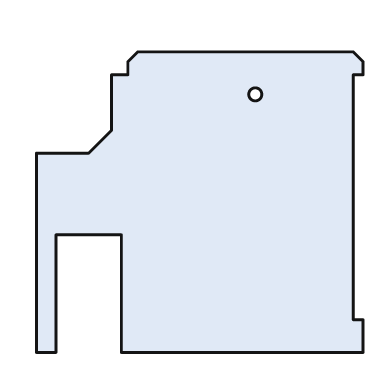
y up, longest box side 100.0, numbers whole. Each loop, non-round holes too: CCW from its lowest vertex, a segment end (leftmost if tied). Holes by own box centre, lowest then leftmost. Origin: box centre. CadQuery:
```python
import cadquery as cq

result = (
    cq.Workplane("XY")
    .moveTo(-50.0, -46.0)
    .lineTo(-44.0, -46.0)
    .lineTo(-44.0, -10.0)
    .lineTo(-24.0, -10.0)
    .lineTo(-24.0, -46.0)
    .lineTo(50.0, -46.0)
    .lineTo(50.0, -36.0)
    .lineTo(47.0, -36.0)
    .lineTo(47.0, 39.0)
    .lineTo(50.0, 39.0)
    .lineTo(50.0, 43.0)
    .lineTo(47.0, 46.0)
    .lineTo(-19.0, 46.0)
    .lineTo(-22.0, 43.0)
    .lineTo(-22.0, 39.0)
    .lineTo(-27.0, 39.0)
    .lineTo(-27.0, 22.0)
    .lineTo(-34.0, 15.0)
    .lineTo(-50.0, 15.0)
    .close()
    .moveTo(17.0, 33.0)
    .circle(2.0)
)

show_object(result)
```